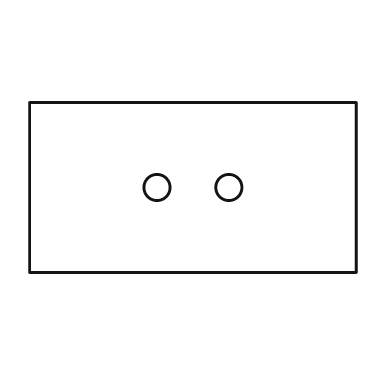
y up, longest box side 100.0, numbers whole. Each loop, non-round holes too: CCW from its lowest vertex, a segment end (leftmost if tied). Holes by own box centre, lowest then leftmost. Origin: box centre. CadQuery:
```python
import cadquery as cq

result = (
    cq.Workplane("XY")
    .moveTo(-50.0, -26.0)
    .lineTo(50.0, -26.0)
    .lineTo(50.0, 26.0)
    .lineTo(-50.0, 26.0)
    .close()
    .moveTo(-11.0, 0.0)
    .circle(4.0)
    .moveTo(11.0, 0.0)
    .circle(4.0)
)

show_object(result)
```